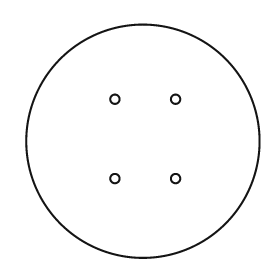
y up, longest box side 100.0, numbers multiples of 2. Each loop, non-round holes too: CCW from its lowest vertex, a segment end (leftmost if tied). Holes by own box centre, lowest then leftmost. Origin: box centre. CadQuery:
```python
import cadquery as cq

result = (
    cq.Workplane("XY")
    .moveTo(0.0, 0.0)
    .circle(50.0)
    .moveTo(-12.0, -16.0)
    .circle(2.0)
    .moveTo(14.0, -16.0)
    .circle(2.0)
    .moveTo(-12.0, 18.0)
    .circle(2.0)
    .moveTo(14.0, 18.0)
    .circle(2.0)
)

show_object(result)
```